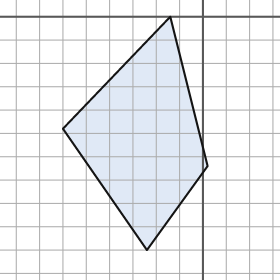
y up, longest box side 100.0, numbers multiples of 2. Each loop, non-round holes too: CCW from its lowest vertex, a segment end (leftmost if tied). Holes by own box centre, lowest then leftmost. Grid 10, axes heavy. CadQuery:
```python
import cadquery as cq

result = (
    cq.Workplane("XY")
    .moveTo(-24.0, -100.0)
    .lineTo(2.0, -64.0)
    .lineTo(-14.0, 0.0)
    .lineTo(-60.0, -48.0)
    .close()
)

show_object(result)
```